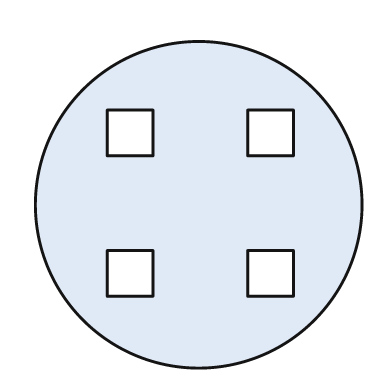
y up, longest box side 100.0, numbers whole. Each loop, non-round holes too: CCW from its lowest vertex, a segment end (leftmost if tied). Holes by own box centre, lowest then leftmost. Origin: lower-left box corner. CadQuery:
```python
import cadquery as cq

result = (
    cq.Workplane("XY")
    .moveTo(50.0, 50.0)
    .circle(50.0)
    .moveTo(22.0, 22.0)
    .lineTo(36.0, 22.0)
    .lineTo(36.0, 36.0)
    .lineTo(22.0, 36.0)
    .close()
    .moveTo(65.0, 22.0)
    .lineTo(79.0, 22.0)
    .lineTo(79.0, 36.0)
    .lineTo(65.0, 36.0)
    .close()
    .moveTo(22.0, 65.0)
    .lineTo(36.0, 65.0)
    .lineTo(36.0, 79.0)
    .lineTo(22.0, 79.0)
    .close()
    .moveTo(65.0, 65.0)
    .lineTo(79.0, 65.0)
    .lineTo(79.0, 79.0)
    .lineTo(65.0, 79.0)
    .close()
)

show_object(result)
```